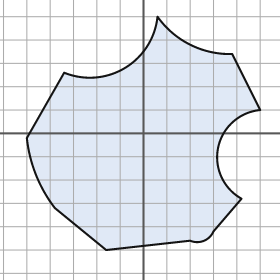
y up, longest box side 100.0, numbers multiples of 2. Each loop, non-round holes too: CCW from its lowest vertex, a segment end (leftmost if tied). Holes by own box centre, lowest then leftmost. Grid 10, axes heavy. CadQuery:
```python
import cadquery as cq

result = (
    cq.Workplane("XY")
    .moveTo(-16.0, -50.0)
    .lineTo(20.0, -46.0)
    .threePointArc((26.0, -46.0), (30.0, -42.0))
    .lineTo(42.0, -28.0)
    .threePointArc((32.0, -6.0), (50.0, 10.0))
    .lineTo(38.0, 34.0)
    .threePointArc((20.0, 38.0), (6.0, 50.0))
    .threePointArc((-8.0, 28.0), (-34.0, 26.0))
    .lineTo(-50.0, -2.0)
    .threePointArc((-46.0, -18.0), (-38.0, -32.0))
    .close()
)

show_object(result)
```